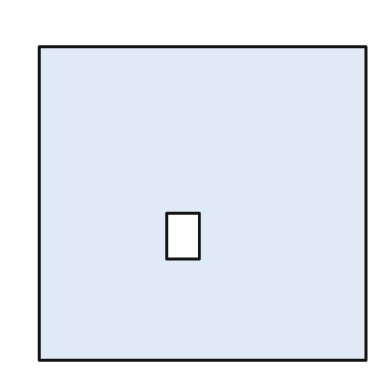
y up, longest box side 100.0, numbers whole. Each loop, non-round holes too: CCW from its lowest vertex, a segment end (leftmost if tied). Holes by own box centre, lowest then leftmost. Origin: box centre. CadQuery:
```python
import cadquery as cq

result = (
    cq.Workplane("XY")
    .moveTo(-50.0, -48.0)
    .lineTo(50.0, -48.0)
    .lineTo(50.0, 48.0)
    .lineTo(-50.0, 48.0)
    .close()
    .moveTo(-11.0, -17.0)
    .lineTo(-1.0, -17.0)
    .lineTo(-1.0, -3.0)
    .lineTo(-11.0, -3.0)
    .close()
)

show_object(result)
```